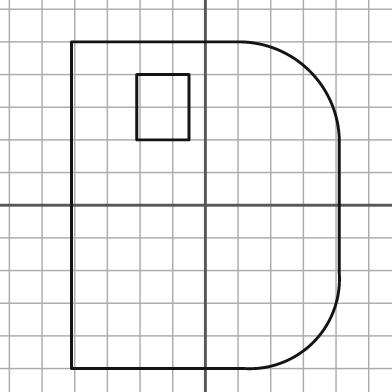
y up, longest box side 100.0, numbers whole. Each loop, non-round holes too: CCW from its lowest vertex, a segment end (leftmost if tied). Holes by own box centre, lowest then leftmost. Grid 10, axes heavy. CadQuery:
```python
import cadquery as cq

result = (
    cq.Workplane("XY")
    .moveTo(-41.0, -50.0)
    .lineTo(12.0, -50.0)
    .threePointArc((33.0, -42.0), (41.0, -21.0))
    .lineTo(41.0, 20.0)
    .threePointArc((32.0, 41.0), (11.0, 50.0))
    .lineTo(-41.0, 50.0)
    .close()
    .moveTo(-21.0, 20.0)
    .lineTo(-5.0, 20.0)
    .lineTo(-5.0, 40.0)
    .lineTo(-21.0, 40.0)
    .close()
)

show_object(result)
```